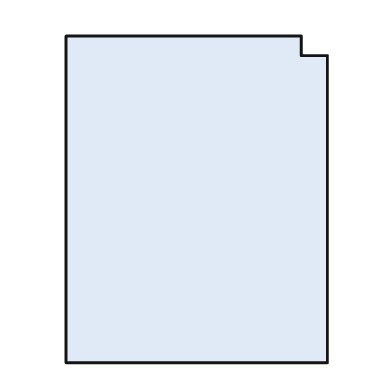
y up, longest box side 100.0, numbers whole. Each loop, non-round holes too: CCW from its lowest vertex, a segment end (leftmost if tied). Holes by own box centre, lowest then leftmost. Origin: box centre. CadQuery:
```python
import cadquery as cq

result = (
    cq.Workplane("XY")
    .moveTo(-40.0, -50.0)
    .lineTo(40.0, -50.0)
    .lineTo(40.0, 44.0)
    .lineTo(32.0, 44.0)
    .lineTo(32.0, 50.0)
    .lineTo(-40.0, 50.0)
    .close()
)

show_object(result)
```